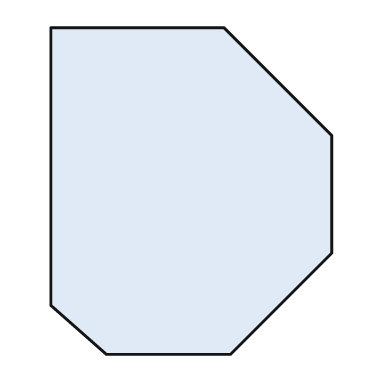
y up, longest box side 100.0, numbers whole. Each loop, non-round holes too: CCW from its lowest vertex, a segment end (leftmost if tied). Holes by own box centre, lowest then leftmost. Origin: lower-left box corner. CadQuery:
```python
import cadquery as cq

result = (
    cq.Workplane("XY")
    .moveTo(17.0, 0.0)
    .lineTo(55.0, 0.0)
    .lineTo(86.0, 31.0)
    .lineTo(86.0, 67.0)
    .lineTo(53.0, 100.0)
    .lineTo(0.0, 100.0)
    .lineTo(0.0, 15.0)
    .close()
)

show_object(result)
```